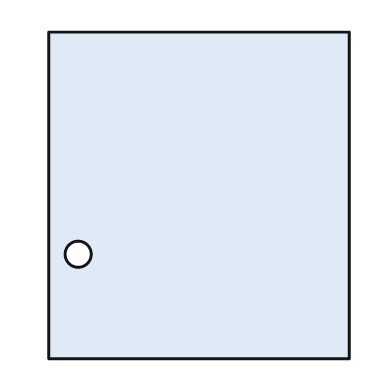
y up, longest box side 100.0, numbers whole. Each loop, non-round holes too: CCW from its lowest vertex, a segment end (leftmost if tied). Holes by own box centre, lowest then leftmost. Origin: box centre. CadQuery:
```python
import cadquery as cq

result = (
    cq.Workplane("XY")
    .moveTo(-46.0, -50.0)
    .lineTo(46.0, -50.0)
    .lineTo(46.0, 50.0)
    .lineTo(-46.0, 50.0)
    .close()
    .moveTo(-37.0, -18.0)
    .circle(4.0)
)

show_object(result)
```